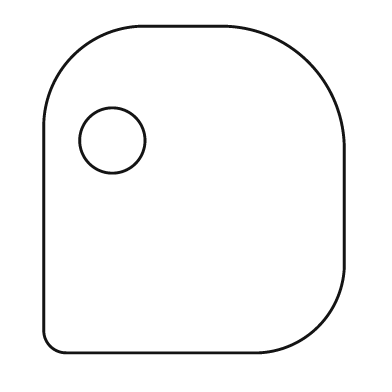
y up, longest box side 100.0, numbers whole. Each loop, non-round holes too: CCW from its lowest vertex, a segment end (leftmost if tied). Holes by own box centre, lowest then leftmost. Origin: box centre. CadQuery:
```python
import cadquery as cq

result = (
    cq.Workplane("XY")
    .moveTo(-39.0, -50.0)
    .lineTo(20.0, -50.0)
    .threePointArc((38.0, -42.0), (46.0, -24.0))
    .lineTo(46.0, 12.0)
    .threePointArc((35.0, 39.0), (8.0, 50.0))
    .lineTo(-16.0, 50.0)
    .threePointArc((-37.0, 41.0), (-46.0, 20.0))
    .lineTo(-46.0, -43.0)
    .threePointArc((-44.0, -48.0), (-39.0, -50.0))
    .close()
    .moveTo(-25.0, 15.0)
    .circle(10.0)
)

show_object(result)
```